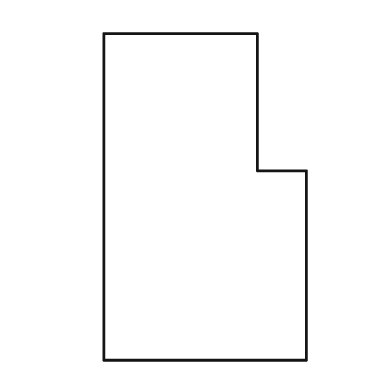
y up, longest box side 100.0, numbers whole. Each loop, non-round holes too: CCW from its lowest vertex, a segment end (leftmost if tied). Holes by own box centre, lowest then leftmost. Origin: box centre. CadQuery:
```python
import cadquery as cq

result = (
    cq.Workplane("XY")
    .moveTo(-31.0, -50.0)
    .lineTo(31.0, -50.0)
    .lineTo(31.0, 8.0)
    .lineTo(16.0, 8.0)
    .lineTo(16.0, 50.0)
    .lineTo(-31.0, 50.0)
    .close()
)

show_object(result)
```